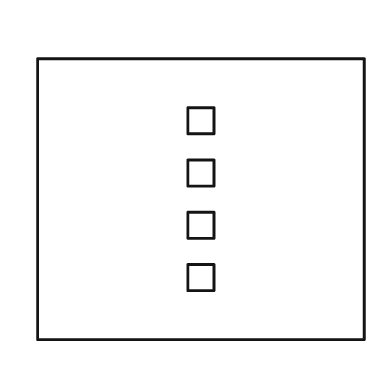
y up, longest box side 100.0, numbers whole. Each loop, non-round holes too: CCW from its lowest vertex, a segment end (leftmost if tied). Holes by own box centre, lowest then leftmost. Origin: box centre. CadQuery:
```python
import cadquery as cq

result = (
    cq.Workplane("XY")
    .moveTo(-50.0, -43.0)
    .lineTo(50.0, -43.0)
    .lineTo(50.0, 43.0)
    .lineTo(-50.0, 43.0)
    .close()
    .moveTo(-4.0, -28.0)
    .lineTo(4.0, -28.0)
    .lineTo(4.0, -20.0)
    .lineTo(-4.0, -20.0)
    .close()
    .moveTo(-4.0, -12.0)
    .lineTo(4.0, -12.0)
    .lineTo(4.0, -4.0)
    .lineTo(-4.0, -4.0)
    .close()
    .moveTo(-4.0, 4.0)
    .lineTo(4.0, 4.0)
    .lineTo(4.0, 12.0)
    .lineTo(-4.0, 12.0)
    .close()
    .moveTo(-4.0, 20.0)
    .lineTo(4.0, 20.0)
    .lineTo(4.0, 28.0)
    .lineTo(-4.0, 28.0)
    .close()
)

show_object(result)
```